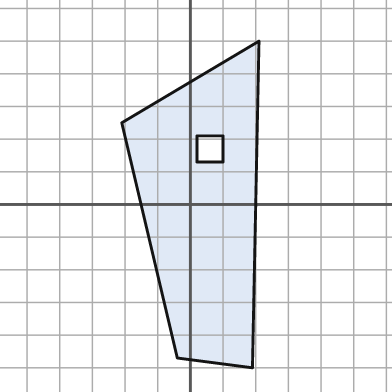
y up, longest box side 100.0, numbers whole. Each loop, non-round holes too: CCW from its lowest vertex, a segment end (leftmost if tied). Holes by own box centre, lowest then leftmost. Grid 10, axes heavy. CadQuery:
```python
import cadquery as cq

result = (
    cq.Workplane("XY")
    .moveTo(19.0, -50.0)
    .lineTo(21.0, 50.0)
    .lineTo(-21.0, 25.0)
    .lineTo(-4.0, -47.0)
    .close()
    .moveTo(2.0, 13.0)
    .lineTo(10.0, 13.0)
    .lineTo(10.0, 21.0)
    .lineTo(2.0, 21.0)
    .close()
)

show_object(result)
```